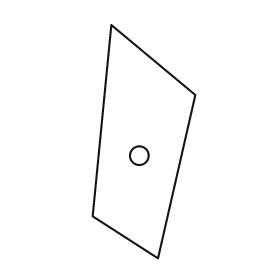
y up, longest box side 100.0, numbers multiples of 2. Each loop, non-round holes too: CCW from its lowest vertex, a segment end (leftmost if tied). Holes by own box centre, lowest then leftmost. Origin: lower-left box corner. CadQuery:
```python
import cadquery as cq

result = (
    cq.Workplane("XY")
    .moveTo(28.0, 0.0)
    .lineTo(44.0, 70.0)
    .lineTo(8.0, 100.0)
    .lineTo(0.0, 18.0)
    .close()
    .moveTo(20.0, 44.0)
    .circle(4.0)
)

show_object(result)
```